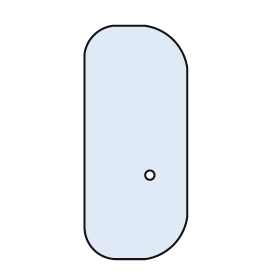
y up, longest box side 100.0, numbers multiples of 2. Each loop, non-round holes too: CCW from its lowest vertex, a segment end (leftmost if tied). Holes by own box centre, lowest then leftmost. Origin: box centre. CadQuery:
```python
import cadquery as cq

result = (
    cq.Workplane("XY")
    .moveTo(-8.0, -50.0)
    .lineTo(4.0, -50.0)
    .threePointArc((16.0, -44.0), (22.0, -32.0))
    .lineTo(22.0, 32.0)
    .threePointArc((16.0, 44.0), (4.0, 50.0))
    .lineTo(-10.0, 50.0)
    .threePointArc((-18.0, 46.0), (-22.0, 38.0))
    .lineTo(-22.0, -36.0)
    .threePointArc((-18.0, -46.0), (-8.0, -50.0))
    .close()
    .moveTo(6.0, -14.0)
    .circle(2.0)
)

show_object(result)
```